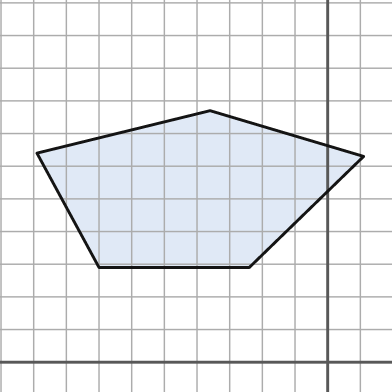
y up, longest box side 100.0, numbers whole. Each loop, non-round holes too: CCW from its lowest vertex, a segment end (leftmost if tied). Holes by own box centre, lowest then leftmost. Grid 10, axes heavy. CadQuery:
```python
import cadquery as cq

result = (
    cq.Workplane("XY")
    .moveTo(-70.0, 29.0)
    .lineTo(-24.0, 29.0)
    .lineTo(11.0, 63.0)
    .lineTo(-36.0, 77.0)
    .lineTo(-89.0, 64.0)
    .close()
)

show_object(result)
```